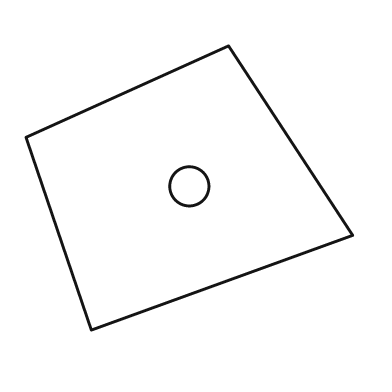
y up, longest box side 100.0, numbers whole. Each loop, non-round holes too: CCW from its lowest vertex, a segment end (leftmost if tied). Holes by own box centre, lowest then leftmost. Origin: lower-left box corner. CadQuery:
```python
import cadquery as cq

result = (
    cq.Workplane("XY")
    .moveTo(20.0, 0.0)
    .lineTo(100.0, 29.0)
    .lineTo(62.0, 87.0)
    .lineTo(0.0, 59.0)
    .close()
    .moveTo(50.0, 44.0)
    .circle(6.0)
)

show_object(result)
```